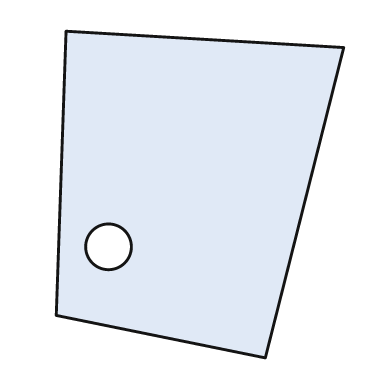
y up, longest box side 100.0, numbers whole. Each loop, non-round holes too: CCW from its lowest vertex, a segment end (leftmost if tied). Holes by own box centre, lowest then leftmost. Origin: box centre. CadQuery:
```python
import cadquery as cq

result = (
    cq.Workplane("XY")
    .moveTo(20.0, -50.0)
    .lineTo(44.0, 45.0)
    .lineTo(-41.0, 50.0)
    .lineTo(-44.0, -37.0)
    .close()
    .moveTo(-28.0, -16.0)
    .circle(7.0)
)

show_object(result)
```